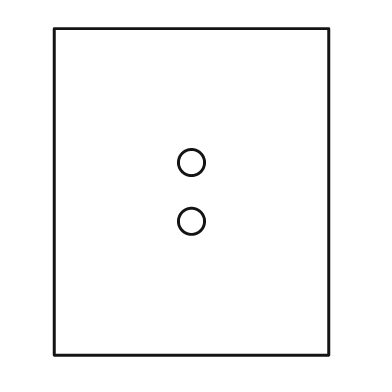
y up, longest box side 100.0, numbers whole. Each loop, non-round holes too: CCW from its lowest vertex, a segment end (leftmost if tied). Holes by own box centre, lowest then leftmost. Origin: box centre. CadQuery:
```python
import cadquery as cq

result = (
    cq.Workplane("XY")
    .moveTo(-42.0, -50.0)
    .lineTo(42.0, -50.0)
    .lineTo(42.0, 50.0)
    .lineTo(-42.0, 50.0)
    .close()
    .moveTo(0.0, -9.0)
    .circle(4.0)
    .moveTo(0.0, 9.0)
    .circle(4.0)
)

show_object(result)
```